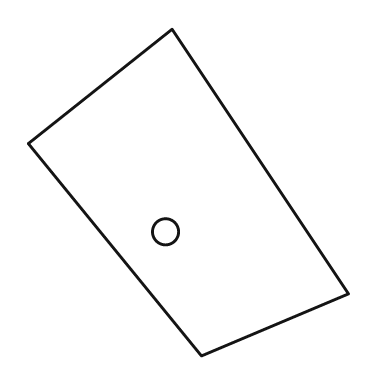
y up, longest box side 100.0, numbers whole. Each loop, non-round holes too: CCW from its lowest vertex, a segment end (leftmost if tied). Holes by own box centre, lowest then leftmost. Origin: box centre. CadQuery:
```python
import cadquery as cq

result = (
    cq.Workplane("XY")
    .moveTo(4.0, -50.0)
    .lineTo(49.0, -31.0)
    .lineTo(-5.0, 50.0)
    .lineTo(-49.0, 15.0)
    .close()
    .moveTo(-7.0, -12.0)
    .circle(4.0)
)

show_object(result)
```